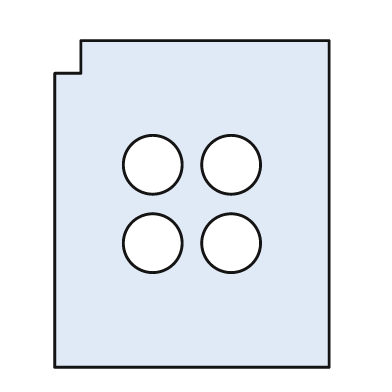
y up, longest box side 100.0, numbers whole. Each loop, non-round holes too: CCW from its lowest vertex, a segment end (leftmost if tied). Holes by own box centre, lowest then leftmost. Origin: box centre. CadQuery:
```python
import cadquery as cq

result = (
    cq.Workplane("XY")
    .moveTo(-42.0, -50.0)
    .lineTo(42.0, -50.0)
    .lineTo(42.0, 50.0)
    .lineTo(-34.0, 50.0)
    .lineTo(-34.0, 40.0)
    .lineTo(-42.0, 40.0)
    .close()
    .moveTo(-12.0, -12.0)
    .circle(9.0)
    .moveTo(12.0, -12.0)
    .circle(9.0)
    .moveTo(-12.0, 12.0)
    .circle(9.0)
    .moveTo(12.0, 12.0)
    .circle(9.0)
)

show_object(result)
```